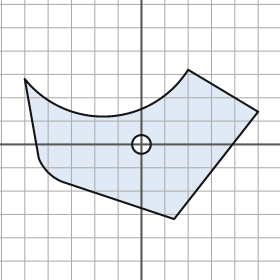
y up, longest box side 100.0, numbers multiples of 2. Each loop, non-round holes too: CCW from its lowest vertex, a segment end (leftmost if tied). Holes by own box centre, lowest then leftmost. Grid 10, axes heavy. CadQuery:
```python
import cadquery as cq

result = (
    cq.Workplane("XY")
    .moveTo(14.0, -32.0)
    .lineTo(50.0, 14.0)
    .lineTo(20.0, 32.0)
    .threePointArc((-14.0, 12.0), (-50.0, 28.0))
    .lineTo(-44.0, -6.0)
    .threePointArc((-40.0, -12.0), (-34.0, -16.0))
    .close()
    .moveTo(0.0, 0.0)
    .circle(4.0)
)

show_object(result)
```